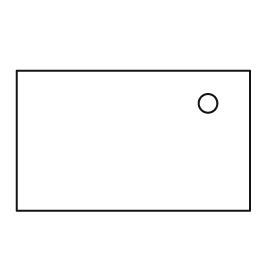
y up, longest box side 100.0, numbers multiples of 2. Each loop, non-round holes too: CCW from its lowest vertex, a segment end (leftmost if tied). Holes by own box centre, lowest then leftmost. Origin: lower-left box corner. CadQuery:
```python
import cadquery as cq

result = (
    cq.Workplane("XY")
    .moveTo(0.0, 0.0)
    .lineTo(100.0, 0.0)
    .lineTo(100.0, 60.0)
    .lineTo(0.0, 60.0)
    .close()
    .moveTo(82.0, 46.0)
    .circle(4.0)
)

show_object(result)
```